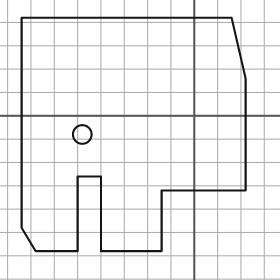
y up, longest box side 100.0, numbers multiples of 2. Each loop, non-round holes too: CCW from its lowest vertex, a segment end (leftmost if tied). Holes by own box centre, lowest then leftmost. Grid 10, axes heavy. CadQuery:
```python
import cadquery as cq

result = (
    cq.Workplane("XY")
    .moveTo(-68.0, -58.0)
    .lineTo(-50.0, -58.0)
    .lineTo(-50.0, -26.0)
    .lineTo(-40.0, -26.0)
    .lineTo(-40.0, -58.0)
    .lineTo(-14.0, -58.0)
    .lineTo(-14.0, -32.0)
    .lineTo(22.0, -32.0)
    .lineTo(22.0, 16.0)
    .lineTo(16.0, 42.0)
    .lineTo(-74.0, 42.0)
    .lineTo(-74.0, -48.0)
    .close()
    .moveTo(-48.0, -8.0)
    .circle(4.0)
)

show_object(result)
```